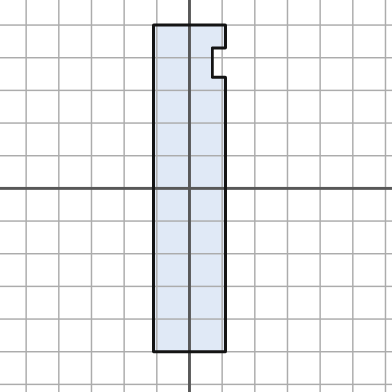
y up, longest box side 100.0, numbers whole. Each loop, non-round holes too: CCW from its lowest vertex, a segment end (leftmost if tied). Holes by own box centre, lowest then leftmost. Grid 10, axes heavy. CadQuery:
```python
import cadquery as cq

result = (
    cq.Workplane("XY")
    .moveTo(-11.0, -50.0)
    .lineTo(11.0, -50.0)
    .lineTo(11.0, 34.0)
    .lineTo(7.0, 34.0)
    .lineTo(7.0, 43.0)
    .lineTo(11.0, 43.0)
    .lineTo(11.0, 50.0)
    .lineTo(-11.0, 50.0)
    .close()
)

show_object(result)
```